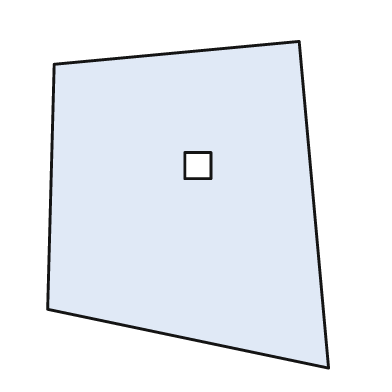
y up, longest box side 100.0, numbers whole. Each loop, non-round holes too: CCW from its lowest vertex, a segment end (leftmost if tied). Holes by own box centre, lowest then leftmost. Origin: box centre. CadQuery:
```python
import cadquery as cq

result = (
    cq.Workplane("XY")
    .moveTo(43.0, -50.0)
    .lineTo(34.0, 50.0)
    .lineTo(-41.0, 43.0)
    .lineTo(-43.0, -32.0)
    .close()
    .moveTo(-1.0, 8.0)
    .lineTo(7.0, 8.0)
    .lineTo(7.0, 16.0)
    .lineTo(-1.0, 16.0)
    .close()
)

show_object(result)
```